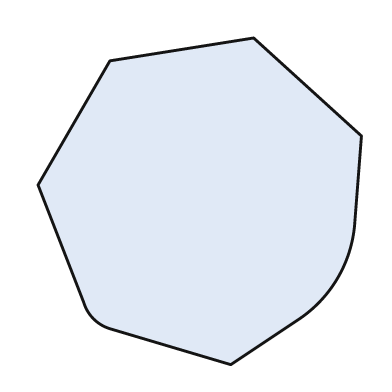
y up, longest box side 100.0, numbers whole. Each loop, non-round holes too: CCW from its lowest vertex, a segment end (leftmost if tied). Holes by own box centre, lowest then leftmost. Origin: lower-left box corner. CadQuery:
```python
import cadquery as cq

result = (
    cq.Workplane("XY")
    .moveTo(59.0, 0.0)
    .lineTo(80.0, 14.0)
    .threePointArc((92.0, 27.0), (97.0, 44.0))
    .lineTo(99.0, 70.0)
    .lineTo(66.0, 100.0)
    .lineTo(22.0, 93.0)
    .lineTo(0.0, 55.0)
    .lineTo(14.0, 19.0)
    .threePointArc((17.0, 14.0), (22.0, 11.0))
    .close()
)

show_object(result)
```